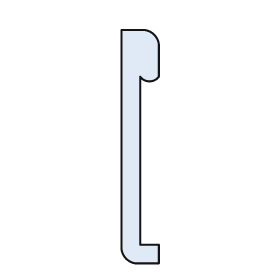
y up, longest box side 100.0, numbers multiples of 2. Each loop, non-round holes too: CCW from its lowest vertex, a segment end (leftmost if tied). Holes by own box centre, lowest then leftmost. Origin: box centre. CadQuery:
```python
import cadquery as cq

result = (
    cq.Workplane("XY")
    .moveTo(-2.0, -50.0)
    .lineTo(8.0, -50.0)
    .lineTo(8.0, -42.0)
    .lineTo(0.0, -42.0)
    .lineTo(0.0, 30.0)
    .threePointArc((4.0, 28.0), (8.0, 30.0))
    .lineTo(8.0, 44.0)
    .threePointArc((6.0, 48.0), (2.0, 50.0))
    .lineTo(-8.0, 50.0)
    .lineTo(-8.0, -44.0)
    .threePointArc((-6.0, -48.0), (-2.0, -50.0))
    .close()
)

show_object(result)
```